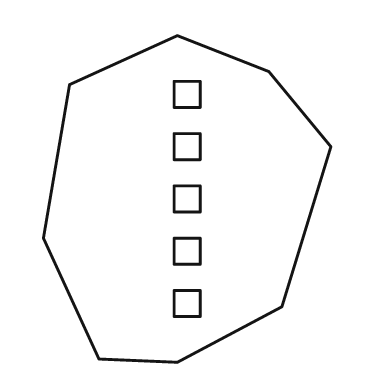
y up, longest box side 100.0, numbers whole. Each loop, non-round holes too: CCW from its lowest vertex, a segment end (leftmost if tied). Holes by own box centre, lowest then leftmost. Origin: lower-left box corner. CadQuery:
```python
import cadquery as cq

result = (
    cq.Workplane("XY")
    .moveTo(41.0, 0.0)
    .lineTo(73.0, 17.0)
    .lineTo(88.0, 66.0)
    .lineTo(69.0, 89.0)
    .lineTo(41.0, 100.0)
    .lineTo(8.0, 85.0)
    .lineTo(0.0, 38.0)
    .lineTo(17.0, 1.0)
    .close()
    .moveTo(40.0, 14.0)
    .lineTo(48.0, 14.0)
    .lineTo(48.0, 22.0)
    .lineTo(40.0, 22.0)
    .close()
    .moveTo(40.0, 30.0)
    .lineTo(48.0, 30.0)
    .lineTo(48.0, 38.0)
    .lineTo(40.0, 38.0)
    .close()
    .moveTo(40.0, 46.0)
    .lineTo(48.0, 46.0)
    .lineTo(48.0, 54.0)
    .lineTo(40.0, 54.0)
    .close()
    .moveTo(40.0, 62.0)
    .lineTo(48.0, 62.0)
    .lineTo(48.0, 70.0)
    .lineTo(40.0, 70.0)
    .close()
    .moveTo(40.0, 78.0)
    .lineTo(48.0, 78.0)
    .lineTo(48.0, 86.0)
    .lineTo(40.0, 86.0)
    .close()
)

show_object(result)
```